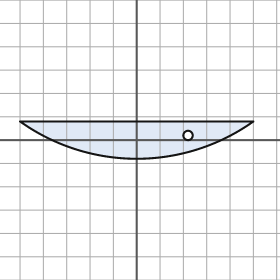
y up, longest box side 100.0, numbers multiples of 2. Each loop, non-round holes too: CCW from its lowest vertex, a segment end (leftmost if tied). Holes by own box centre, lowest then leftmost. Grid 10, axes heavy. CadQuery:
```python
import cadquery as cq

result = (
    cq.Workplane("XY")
    .moveTo(-50.0, 8.0)
    .threePointArc((0.0, -8.0), (50.0, 8.0))
    .close()
    .moveTo(22.0, 2.0)
    .circle(2.0)
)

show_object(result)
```